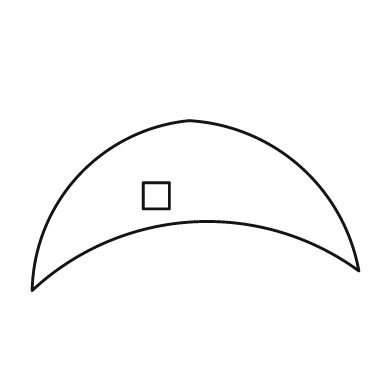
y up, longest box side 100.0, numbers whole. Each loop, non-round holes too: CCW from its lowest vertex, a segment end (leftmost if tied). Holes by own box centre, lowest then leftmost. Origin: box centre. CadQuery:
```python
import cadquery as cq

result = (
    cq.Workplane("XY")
    .moveTo(-50.0, -26.0)
    .threePointArc((-1.0, -5.0), (50.0, -20.0))
    .threePointArc((32.0, 12.0), (-2.0, 26.0))
    .threePointArc((-36.0, 9.0), (-50.0, -26.0))
    .close()
    .moveTo(-16.0, -1.0)
    .lineTo(-8.0, -1.0)
    .lineTo(-8.0, 7.0)
    .lineTo(-16.0, 7.0)
    .close()
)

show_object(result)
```